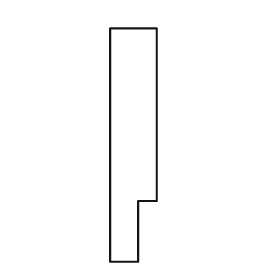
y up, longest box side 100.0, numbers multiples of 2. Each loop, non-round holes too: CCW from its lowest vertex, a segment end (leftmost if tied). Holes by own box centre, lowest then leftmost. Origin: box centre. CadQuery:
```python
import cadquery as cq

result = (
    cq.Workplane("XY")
    .moveTo(-10.0, -50.0)
    .lineTo(2.0, -50.0)
    .lineTo(2.0, -24.0)
    .lineTo(10.0, -24.0)
    .lineTo(10.0, 50.0)
    .lineTo(-10.0, 50.0)
    .close()
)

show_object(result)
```